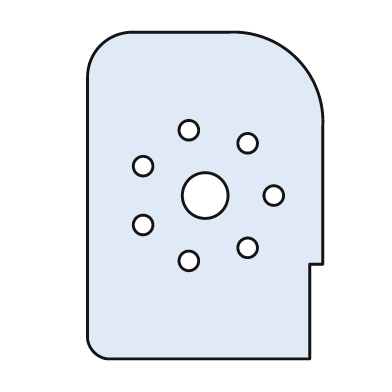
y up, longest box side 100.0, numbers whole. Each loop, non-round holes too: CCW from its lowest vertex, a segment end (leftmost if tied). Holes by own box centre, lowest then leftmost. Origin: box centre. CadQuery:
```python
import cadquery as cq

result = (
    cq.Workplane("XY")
    .moveTo(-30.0, -50.0)
    .lineTo(32.0, -50.0)
    .lineTo(32.0, -21.0)
    .lineTo(36.0, -21.0)
    .lineTo(36.0, 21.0)
    .threePointArc((28.0, 42.0), (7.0, 50.0))
    .lineTo(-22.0, 50.0)
    .threePointArc((-32.0, 46.0), (-36.0, 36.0))
    .lineTo(-36.0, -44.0)
    .threePointArc((-34.0, -48.0), (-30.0, -50.0))
    .close()
    .moveTo(-5.0, -20.0)
    .circle(3.0)
    .moveTo(13.0, -16.0)
    .circle(3.0)
    .moveTo(-19.0, -9.0)
    .circle(3.0)
    .moveTo(0.0, 0.0)
    .circle(7.0)
    .moveTo(21.0, 0.0)
    .circle(3.0)
    .moveTo(-19.0, 9.0)
    .circle(3.0)
    .moveTo(13.0, 16.0)
    .circle(3.0)
    .moveTo(-5.0, 20.0)
    .circle(3.0)
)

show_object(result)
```